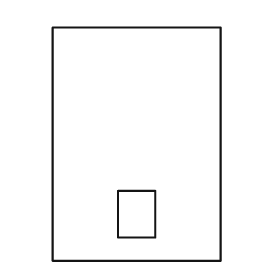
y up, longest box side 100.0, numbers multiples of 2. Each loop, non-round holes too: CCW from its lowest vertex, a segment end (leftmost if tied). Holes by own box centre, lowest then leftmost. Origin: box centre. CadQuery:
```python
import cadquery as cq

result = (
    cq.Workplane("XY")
    .moveTo(-36.0, -50.0)
    .lineTo(36.0, -50.0)
    .lineTo(36.0, 50.0)
    .lineTo(-36.0, 50.0)
    .close()
    .moveTo(-8.0, -40.0)
    .lineTo(8.0, -40.0)
    .lineTo(8.0, -20.0)
    .lineTo(-8.0, -20.0)
    .close()
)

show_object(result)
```